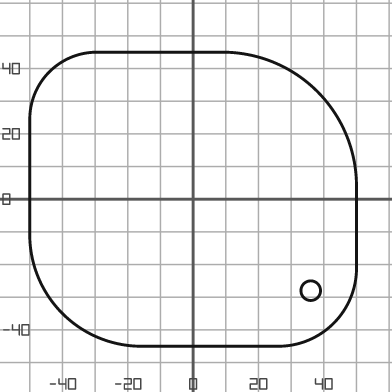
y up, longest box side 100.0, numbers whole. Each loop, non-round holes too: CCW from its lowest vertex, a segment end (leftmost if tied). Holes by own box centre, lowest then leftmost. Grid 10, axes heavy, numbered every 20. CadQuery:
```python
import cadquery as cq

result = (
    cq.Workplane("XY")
    .moveTo(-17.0, -45.0)
    .lineTo(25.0, -45.0)
    .threePointArc((43.0, -38.0), (50.0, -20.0))
    .lineTo(50.0, 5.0)
    .threePointArc((38.0, 33.0), (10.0, 45.0))
    .lineTo(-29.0, 45.0)
    .threePointArc((-44.0, 39.0), (-50.0, 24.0))
    .lineTo(-50.0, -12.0)
    .threePointArc((-40.0, -35.0), (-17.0, -45.0))
    .close()
    .moveTo(36.0, -28.0)
    .circle(3.0)
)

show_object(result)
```